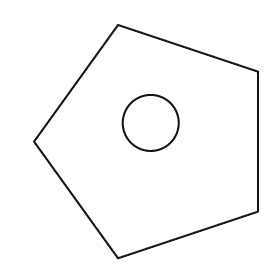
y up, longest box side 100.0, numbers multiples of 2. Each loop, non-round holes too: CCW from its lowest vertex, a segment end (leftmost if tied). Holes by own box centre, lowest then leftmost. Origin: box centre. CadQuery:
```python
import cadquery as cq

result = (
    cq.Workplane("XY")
    .moveTo(-12.0, -50.0)
    .lineTo(48.0, -30.0)
    .lineTo(48.0, 30.0)
    .lineTo(-12.0, 50.0)
    .lineTo(-48.0, 0.0)
    .close()
    .moveTo(2.0, 8.0)
    .circle(12.0)
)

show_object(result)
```